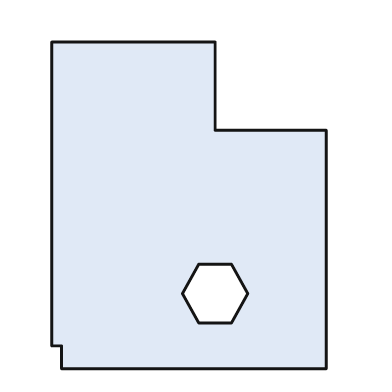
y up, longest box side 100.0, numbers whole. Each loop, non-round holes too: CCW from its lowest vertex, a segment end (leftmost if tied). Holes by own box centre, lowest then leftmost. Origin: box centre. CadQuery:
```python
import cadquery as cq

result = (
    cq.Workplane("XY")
    .moveTo(-39.0, -50.0)
    .lineTo(42.0, -50.0)
    .lineTo(42.0, 23.0)
    .lineTo(8.0, 23.0)
    .lineTo(8.0, 50.0)
    .lineTo(-42.0, 50.0)
    .lineTo(-42.0, -43.0)
    .lineTo(-39.0, -43.0)
    .close()
    .moveTo(3.0, -36.0)
    .lineTo(13.0, -36.0)
    .lineTo(18.0, -27.0)
    .lineTo(13.0, -18.0)
    .lineTo(3.0, -18.0)
    .lineTo(-2.0, -27.0)
    .close()
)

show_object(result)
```